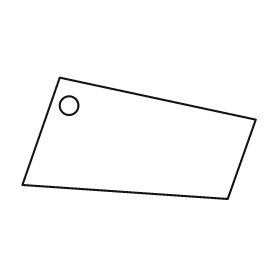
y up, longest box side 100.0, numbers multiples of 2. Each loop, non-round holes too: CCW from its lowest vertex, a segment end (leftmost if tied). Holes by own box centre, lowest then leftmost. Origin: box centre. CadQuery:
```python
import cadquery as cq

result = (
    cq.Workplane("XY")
    .moveTo(38.0, -26.0)
    .lineTo(50.0, 8.0)
    .lineTo(-34.0, 26.0)
    .lineTo(-50.0, -20.0)
    .close()
    .moveTo(-30.0, 14.0)
    .circle(4.0)
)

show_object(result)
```